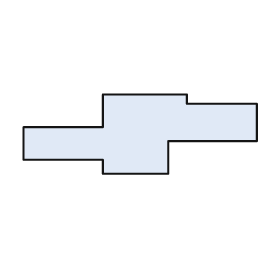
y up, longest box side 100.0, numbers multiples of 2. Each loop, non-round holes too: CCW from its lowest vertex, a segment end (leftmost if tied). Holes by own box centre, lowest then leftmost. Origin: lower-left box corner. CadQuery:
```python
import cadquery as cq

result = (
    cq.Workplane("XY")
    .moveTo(34.0, 0.0)
    .lineTo(62.0, 0.0)
    .lineTo(62.0, 14.0)
    .lineTo(100.0, 14.0)
    .lineTo(100.0, 30.0)
    .lineTo(70.0, 30.0)
    .lineTo(70.0, 34.0)
    .lineTo(34.0, 34.0)
    .lineTo(34.0, 20.0)
    .lineTo(0.0, 20.0)
    .lineTo(0.0, 6.0)
    .lineTo(34.0, 6.0)
    .close()
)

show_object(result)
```